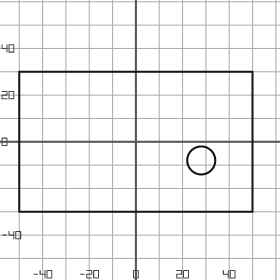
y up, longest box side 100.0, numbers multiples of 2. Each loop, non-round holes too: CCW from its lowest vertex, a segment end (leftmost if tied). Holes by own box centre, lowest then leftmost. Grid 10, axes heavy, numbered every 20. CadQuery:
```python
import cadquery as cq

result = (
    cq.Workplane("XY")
    .moveTo(-50.0, -30.0)
    .lineTo(50.0, -30.0)
    .lineTo(50.0, 30.0)
    .lineTo(-50.0, 30.0)
    .close()
    .moveTo(28.0, -8.0)
    .circle(6.0)
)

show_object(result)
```